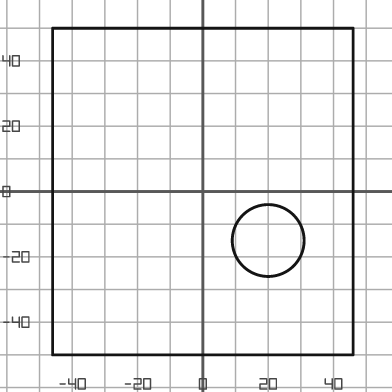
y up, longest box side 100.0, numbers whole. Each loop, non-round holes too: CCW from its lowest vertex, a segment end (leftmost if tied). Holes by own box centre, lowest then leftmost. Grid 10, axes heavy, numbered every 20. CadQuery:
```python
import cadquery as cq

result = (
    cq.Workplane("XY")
    .moveTo(-46.0, -50.0)
    .lineTo(46.0, -50.0)
    .lineTo(46.0, 50.0)
    .lineTo(-46.0, 50.0)
    .close()
    .moveTo(20.0, -15.0)
    .circle(11.0)
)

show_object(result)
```